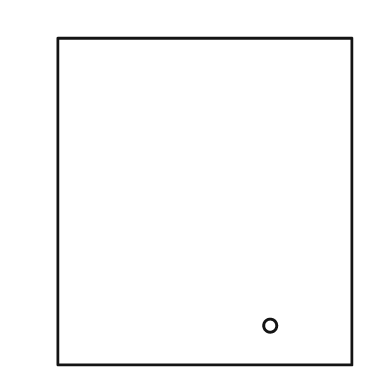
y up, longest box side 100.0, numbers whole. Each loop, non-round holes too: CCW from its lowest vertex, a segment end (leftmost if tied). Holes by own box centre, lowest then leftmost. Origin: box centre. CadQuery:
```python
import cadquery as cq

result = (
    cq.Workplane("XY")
    .moveTo(-45.0, -50.0)
    .lineTo(45.0, -50.0)
    .lineTo(45.0, 50.0)
    .lineTo(-45.0, 50.0)
    .close()
    .moveTo(20.0, -38.0)
    .circle(2.0)
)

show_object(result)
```